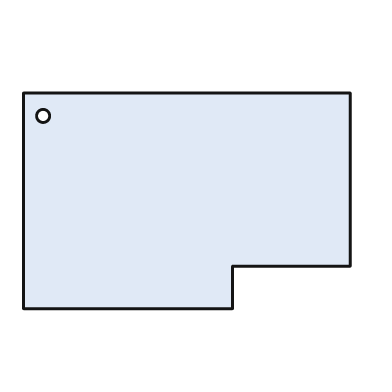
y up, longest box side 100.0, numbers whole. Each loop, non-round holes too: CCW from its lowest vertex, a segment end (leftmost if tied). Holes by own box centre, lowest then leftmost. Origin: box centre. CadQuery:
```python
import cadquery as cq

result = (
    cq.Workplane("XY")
    .moveTo(-50.0, -33.0)
    .lineTo(14.0, -33.0)
    .lineTo(14.0, -20.0)
    .lineTo(50.0, -20.0)
    .lineTo(50.0, 33.0)
    .lineTo(-50.0, 33.0)
    .close()
    .moveTo(-44.0, 26.0)
    .circle(2.0)
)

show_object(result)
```